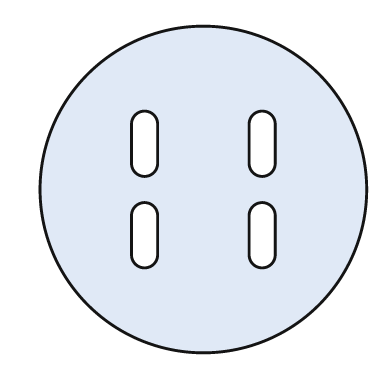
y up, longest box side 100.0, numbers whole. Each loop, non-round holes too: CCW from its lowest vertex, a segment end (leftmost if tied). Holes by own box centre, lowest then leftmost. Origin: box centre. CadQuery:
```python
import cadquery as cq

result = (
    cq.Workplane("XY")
    .moveTo(0.0, 0.0)
    .circle(50.0)
    .moveTo(-22.0, -20.0)
    .threePointArc((-18.0, -24.0), (-14.0, -20.0))
    .lineTo(-14.0, -8.0)
    .threePointArc((-18.0, -4.0), (-22.0, -8.0))
    .close()
    .moveTo(14.0, -20.0)
    .threePointArc((18.0, -24.0), (22.0, -20.0))
    .lineTo(22.0, -8.0)
    .threePointArc((18.0, -4.0), (14.0, -8.0))
    .close()
    .moveTo(-22.0, 8.0)
    .threePointArc((-18.0, 4.0), (-14.0, 8.0))
    .lineTo(-14.0, 20.0)
    .threePointArc((-18.0, 24.0), (-22.0, 20.0))
    .close()
    .moveTo(14.0, 8.0)
    .threePointArc((18.0, 4.0), (22.0, 8.0))
    .lineTo(22.0, 20.0)
    .threePointArc((18.0, 24.0), (14.0, 20.0))
    .close()
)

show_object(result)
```